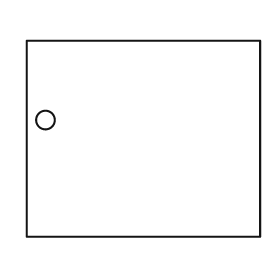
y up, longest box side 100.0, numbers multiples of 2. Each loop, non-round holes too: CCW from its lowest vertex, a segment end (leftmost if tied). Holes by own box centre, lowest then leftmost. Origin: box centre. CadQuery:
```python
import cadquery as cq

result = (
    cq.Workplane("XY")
    .moveTo(-50.0, -42.0)
    .lineTo(50.0, -42.0)
    .lineTo(50.0, 42.0)
    .lineTo(-50.0, 42.0)
    .close()
    .moveTo(-42.0, 8.0)
    .circle(4.0)
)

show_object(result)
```